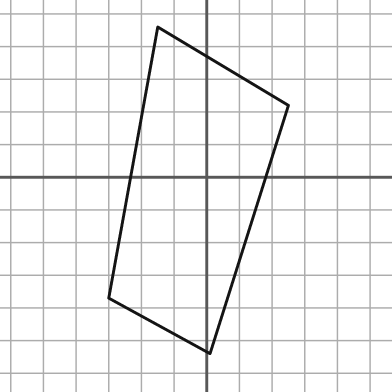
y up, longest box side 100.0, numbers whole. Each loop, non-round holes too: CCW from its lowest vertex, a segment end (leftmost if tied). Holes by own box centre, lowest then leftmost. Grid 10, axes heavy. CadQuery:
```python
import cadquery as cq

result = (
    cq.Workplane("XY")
    .moveTo(1.0, -54.0)
    .lineTo(25.0, 22.0)
    .lineTo(-15.0, 46.0)
    .lineTo(-30.0, -37.0)
    .close()
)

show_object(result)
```